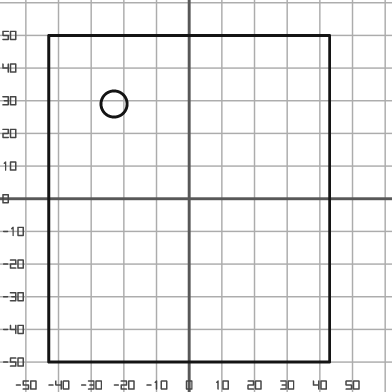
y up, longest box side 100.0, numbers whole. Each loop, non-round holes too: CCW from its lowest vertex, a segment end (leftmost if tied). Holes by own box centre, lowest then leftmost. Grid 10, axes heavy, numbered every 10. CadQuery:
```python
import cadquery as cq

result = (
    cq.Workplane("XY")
    .moveTo(-43.0, -50.0)
    .lineTo(43.0, -50.0)
    .lineTo(43.0, 50.0)
    .lineTo(-43.0, 50.0)
    .close()
    .moveTo(-23.0, 29.0)
    .circle(4.0)
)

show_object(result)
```